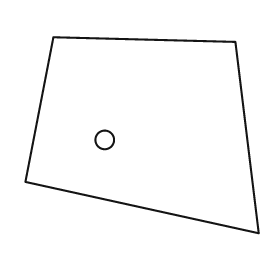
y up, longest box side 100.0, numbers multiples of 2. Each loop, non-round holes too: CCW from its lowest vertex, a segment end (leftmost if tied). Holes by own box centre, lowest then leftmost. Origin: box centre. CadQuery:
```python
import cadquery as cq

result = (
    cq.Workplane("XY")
    .moveTo(50.0, -42.0)
    .lineTo(40.0, 40.0)
    .lineTo(-38.0, 42.0)
    .lineTo(-50.0, -20.0)
    .close()
    .moveTo(-16.0, -2.0)
    .circle(4.0)
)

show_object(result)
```